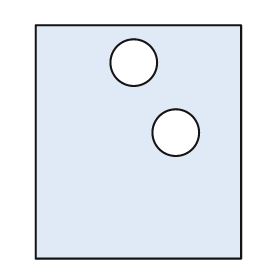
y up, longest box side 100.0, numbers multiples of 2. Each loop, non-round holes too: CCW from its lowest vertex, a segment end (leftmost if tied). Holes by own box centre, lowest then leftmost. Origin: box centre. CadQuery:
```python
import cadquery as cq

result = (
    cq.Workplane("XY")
    .moveTo(-44.0, -50.0)
    .lineTo(44.0, -50.0)
    .lineTo(44.0, 50.0)
    .lineTo(-44.0, 50.0)
    .close()
    .moveTo(16.0, 4.0)
    .circle(10.0)
    .moveTo(-2.0, 34.0)
    .circle(10.0)
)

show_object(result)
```